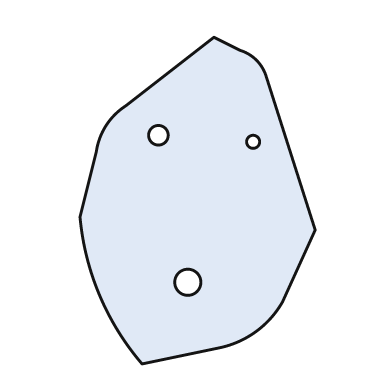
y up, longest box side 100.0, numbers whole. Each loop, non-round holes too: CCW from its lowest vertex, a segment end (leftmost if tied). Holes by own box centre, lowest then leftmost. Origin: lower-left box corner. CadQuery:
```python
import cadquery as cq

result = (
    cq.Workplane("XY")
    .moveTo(19.0, 0.0)
    .lineTo(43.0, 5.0)
    .threePointArc((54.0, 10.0), (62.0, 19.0))
    .lineTo(72.0, 41.0)
    .lineTo(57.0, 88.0)
    .threePointArc((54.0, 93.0), (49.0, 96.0))
    .lineTo(41.0, 100.0)
    .lineTo(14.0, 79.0)
    .threePointArc((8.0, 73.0), (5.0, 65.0))
    .lineTo(0.0, 45.0)
    .threePointArc((6.0, 21.0), (19.0, 0.0))
    .close()
    .moveTo(33.0, 25.0)
    .circle(4.0)
    .moveTo(53.0, 68.0)
    .circle(2.0)
    .moveTo(24.0, 70.0)
    .circle(3.0)
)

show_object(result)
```